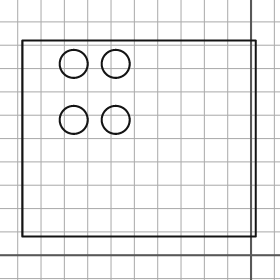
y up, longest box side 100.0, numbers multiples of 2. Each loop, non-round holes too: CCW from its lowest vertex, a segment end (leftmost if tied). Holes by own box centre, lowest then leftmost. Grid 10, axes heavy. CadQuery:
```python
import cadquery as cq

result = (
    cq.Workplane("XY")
    .moveTo(-98.0, 8.0)
    .lineTo(2.0, 8.0)
    .lineTo(2.0, 92.0)
    .lineTo(-98.0, 92.0)
    .close()
    .moveTo(-76.0, 58.0)
    .circle(6.0)
    .moveTo(-58.0, 58.0)
    .circle(6.0)
    .moveTo(-76.0, 82.0)
    .circle(6.0)
    .moveTo(-58.0, 82.0)
    .circle(6.0)
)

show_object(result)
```